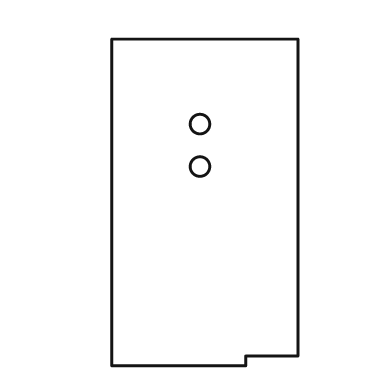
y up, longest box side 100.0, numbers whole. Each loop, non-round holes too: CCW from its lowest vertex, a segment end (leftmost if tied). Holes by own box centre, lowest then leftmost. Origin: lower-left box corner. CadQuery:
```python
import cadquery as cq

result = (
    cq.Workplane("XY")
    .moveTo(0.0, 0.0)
    .lineTo(41.0, 0.0)
    .lineTo(41.0, 3.0)
    .lineTo(57.0, 3.0)
    .lineTo(57.0, 100.0)
    .lineTo(0.0, 100.0)
    .close()
    .moveTo(27.0, 61.0)
    .circle(3.0)
    .moveTo(27.0, 74.0)
    .circle(3.0)
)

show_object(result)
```